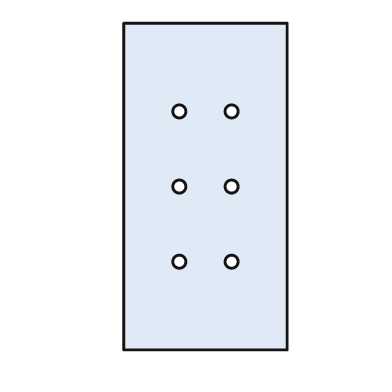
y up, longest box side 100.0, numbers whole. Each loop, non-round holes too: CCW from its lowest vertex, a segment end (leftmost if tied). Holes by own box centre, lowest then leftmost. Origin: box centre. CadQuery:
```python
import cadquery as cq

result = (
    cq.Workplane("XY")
    .moveTo(-25.0, -50.0)
    .lineTo(25.0, -50.0)
    .lineTo(25.0, 50.0)
    .lineTo(-25.0, 50.0)
    .close()
    .moveTo(-8.0, -23.0)
    .circle(2.0)
    .moveTo(8.0, -23.0)
    .circle(2.0)
    .moveTo(-8.0, 0.0)
    .circle(2.0)
    .moveTo(8.0, 0.0)
    .circle(2.0)
    .moveTo(-8.0, 23.0)
    .circle(2.0)
    .moveTo(8.0, 23.0)
    .circle(2.0)
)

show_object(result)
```